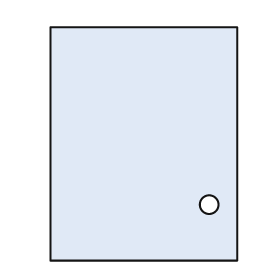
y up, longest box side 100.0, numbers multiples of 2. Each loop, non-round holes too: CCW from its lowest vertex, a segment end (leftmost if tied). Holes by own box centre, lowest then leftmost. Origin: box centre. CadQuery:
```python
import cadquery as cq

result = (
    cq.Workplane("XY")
    .moveTo(-40.0, -50.0)
    .lineTo(40.0, -50.0)
    .lineTo(40.0, 50.0)
    .lineTo(-40.0, 50.0)
    .close()
    .moveTo(28.0, -26.0)
    .circle(4.0)
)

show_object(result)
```